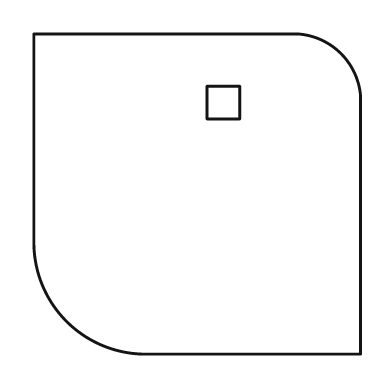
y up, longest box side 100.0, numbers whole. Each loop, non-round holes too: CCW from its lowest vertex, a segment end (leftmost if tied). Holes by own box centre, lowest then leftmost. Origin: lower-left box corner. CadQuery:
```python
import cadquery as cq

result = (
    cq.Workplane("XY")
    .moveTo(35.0, 0.0)
    .lineTo(100.0, 0.0)
    .lineTo(100.0, 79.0)
    .threePointArc((94.0, 92.0), (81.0, 98.0))
    .lineTo(0.0, 98.0)
    .lineTo(0.0, 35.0)
    .threePointArc((10.0, 10.0), (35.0, 0.0))
    .close()
    .moveTo(53.0, 72.0)
    .lineTo(63.0, 72.0)
    .lineTo(63.0, 82.0)
    .lineTo(53.0, 82.0)
    .close()
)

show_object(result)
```